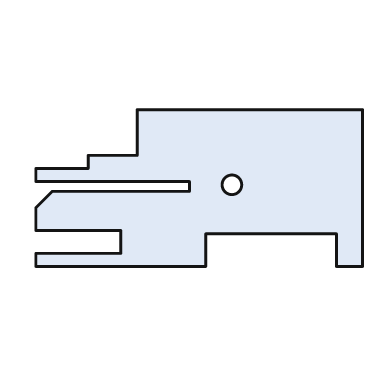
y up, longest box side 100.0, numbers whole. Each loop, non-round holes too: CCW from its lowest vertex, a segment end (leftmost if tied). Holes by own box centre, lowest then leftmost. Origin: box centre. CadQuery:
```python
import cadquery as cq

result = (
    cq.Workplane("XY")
    .moveTo(-50.0, -24.0)
    .lineTo(2.0, -24.0)
    .lineTo(2.0, -14.0)
    .lineTo(42.0, -14.0)
    .lineTo(42.0, -24.0)
    .lineTo(50.0, -24.0)
    .lineTo(50.0, 24.0)
    .lineTo(-19.0, 24.0)
    .lineTo(-19.0, 10.0)
    .lineTo(-34.0, 10.0)
    .lineTo(-34.0, 6.0)
    .lineTo(-50.0, 6.0)
    .lineTo(-50.0, 2.0)
    .lineTo(-3.0, 2.0)
    .lineTo(-3.0, -1.0)
    .lineTo(-45.0, -1.0)
    .lineTo(-50.0, -6.0)
    .lineTo(-50.0, -13.0)
    .lineTo(-24.0, -13.0)
    .lineTo(-24.0, -20.0)
    .lineTo(-50.0, -20.0)
    .close()
    .moveTo(10.0, 1.0)
    .circle(3.0)
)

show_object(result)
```